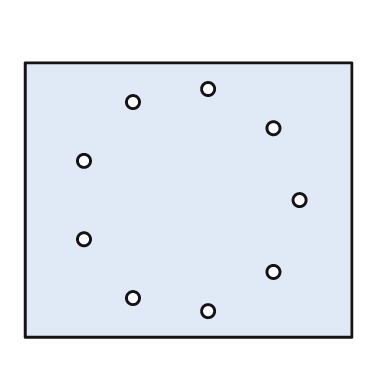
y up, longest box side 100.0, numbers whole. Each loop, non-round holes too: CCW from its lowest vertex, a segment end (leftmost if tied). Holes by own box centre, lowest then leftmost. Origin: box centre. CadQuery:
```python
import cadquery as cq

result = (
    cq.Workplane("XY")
    .moveTo(-50.0, -42.0)
    .lineTo(50.0, -42.0)
    .lineTo(50.0, 42.0)
    .lineTo(-50.0, 42.0)
    .close()
    .moveTo(6.0, -34.0)
    .circle(2.0)
    .moveTo(-17.0, -30.0)
    .circle(2.0)
    .moveTo(26.0, -22.0)
    .circle(2.0)
    .moveTo(-32.0, -12.0)
    .circle(2.0)
    .moveTo(34.0, 0.0)
    .circle(2.0)
    .moveTo(-32.0, 12.0)
    .circle(2.0)
    .moveTo(26.0, 22.0)
    .circle(2.0)
    .moveTo(-17.0, 30.0)
    .circle(2.0)
    .moveTo(6.0, 34.0)
    .circle(2.0)
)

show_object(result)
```